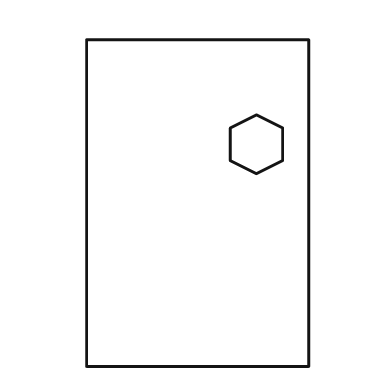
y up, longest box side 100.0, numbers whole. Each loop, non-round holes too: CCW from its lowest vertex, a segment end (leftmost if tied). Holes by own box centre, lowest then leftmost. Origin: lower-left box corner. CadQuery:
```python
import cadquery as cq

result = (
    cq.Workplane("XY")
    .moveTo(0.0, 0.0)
    .lineTo(68.0, 0.0)
    .lineTo(68.0, 100.0)
    .lineTo(0.0, 100.0)
    .close()
    .moveTo(52.0, 59.0)
    .lineTo(60.0, 63.0)
    .lineTo(60.0, 73.0)
    .lineTo(52.0, 77.0)
    .lineTo(44.0, 73.0)
    .lineTo(44.0, 63.0)
    .close()
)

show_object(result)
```